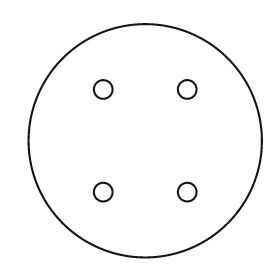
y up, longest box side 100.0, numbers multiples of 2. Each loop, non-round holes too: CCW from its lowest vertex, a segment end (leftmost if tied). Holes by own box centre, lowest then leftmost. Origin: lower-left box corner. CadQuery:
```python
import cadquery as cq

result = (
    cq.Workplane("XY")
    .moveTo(50.0, 50.0)
    .circle(50.0)
    .moveTo(32.0, 28.0)
    .circle(4.0)
    .moveTo(68.0, 28.0)
    .circle(4.0)
    .moveTo(32.0, 72.0)
    .circle(4.0)
    .moveTo(68.0, 72.0)
    .circle(4.0)
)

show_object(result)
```